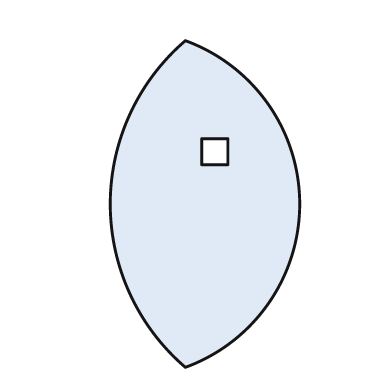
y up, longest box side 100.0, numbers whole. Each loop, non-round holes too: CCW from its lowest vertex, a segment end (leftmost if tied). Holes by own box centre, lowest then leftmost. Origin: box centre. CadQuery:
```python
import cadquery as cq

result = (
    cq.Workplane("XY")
    .moveTo(-6.0, -50.0)
    .threePointArc((29.0, 0.0), (-6.0, 50.0))
    .threePointArc((-29.0, 0.0), (-6.0, -50.0))
    .close()
    .moveTo(-1.0, 12.0)
    .lineTo(7.0, 12.0)
    .lineTo(7.0, 20.0)
    .lineTo(-1.0, 20.0)
    .close()
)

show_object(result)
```